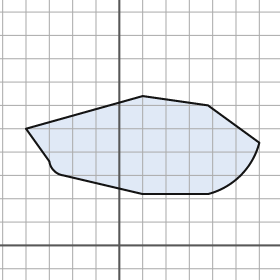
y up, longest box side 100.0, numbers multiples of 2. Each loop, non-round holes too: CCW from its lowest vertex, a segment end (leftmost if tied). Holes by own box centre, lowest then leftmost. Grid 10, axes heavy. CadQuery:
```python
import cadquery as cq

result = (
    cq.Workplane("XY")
    .moveTo(10.0, 22.0)
    .lineTo(38.0, 22.0)
    .threePointArc((52.0, 30.0), (60.0, 44.0))
    .lineTo(38.0, 60.0)
    .lineTo(10.0, 64.0)
    .lineTo(-40.0, 50.0)
    .lineTo(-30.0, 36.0)
    .threePointArc((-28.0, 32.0), (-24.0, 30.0))
    .close()
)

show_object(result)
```